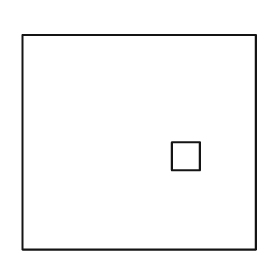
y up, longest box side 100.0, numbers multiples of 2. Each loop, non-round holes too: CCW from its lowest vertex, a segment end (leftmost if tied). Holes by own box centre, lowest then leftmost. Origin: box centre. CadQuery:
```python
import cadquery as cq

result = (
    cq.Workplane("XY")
    .moveTo(-50.0, -46.0)
    .lineTo(50.0, -46.0)
    .lineTo(50.0, 46.0)
    .lineTo(-50.0, 46.0)
    .close()
    .moveTo(14.0, -12.0)
    .lineTo(26.0, -12.0)
    .lineTo(26.0, 0.0)
    .lineTo(14.0, 0.0)
    .close()
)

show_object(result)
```